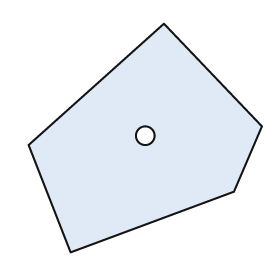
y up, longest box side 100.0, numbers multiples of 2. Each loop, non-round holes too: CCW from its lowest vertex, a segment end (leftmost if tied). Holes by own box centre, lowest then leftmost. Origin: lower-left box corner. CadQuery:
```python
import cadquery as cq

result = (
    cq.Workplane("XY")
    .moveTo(18.0, 0.0)
    .lineTo(88.0, 26.0)
    .lineTo(100.0, 54.0)
    .lineTo(58.0, 98.0)
    .lineTo(0.0, 46.0)
    .close()
    .moveTo(50.0, 50.0)
    .circle(4.0)
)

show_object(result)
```